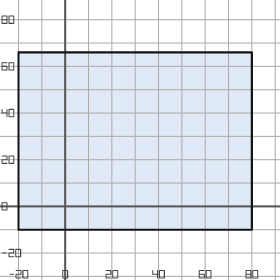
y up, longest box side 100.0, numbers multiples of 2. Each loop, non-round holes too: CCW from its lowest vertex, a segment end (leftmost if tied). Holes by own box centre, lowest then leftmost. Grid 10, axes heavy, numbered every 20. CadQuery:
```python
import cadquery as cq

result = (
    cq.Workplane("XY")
    .moveTo(-20.0, -10.0)
    .lineTo(80.0, -10.0)
    .lineTo(80.0, 66.0)
    .lineTo(-20.0, 66.0)
    .close()
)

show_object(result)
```